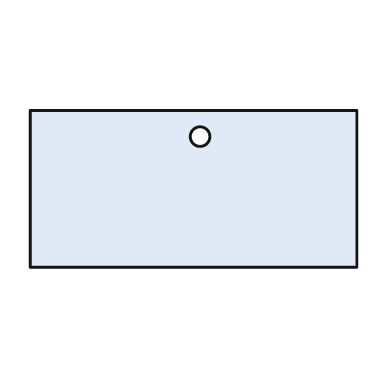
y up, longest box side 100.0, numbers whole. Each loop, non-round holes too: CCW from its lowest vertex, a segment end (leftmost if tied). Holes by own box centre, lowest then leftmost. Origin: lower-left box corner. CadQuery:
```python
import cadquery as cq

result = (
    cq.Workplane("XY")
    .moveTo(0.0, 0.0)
    .lineTo(100.0, 0.0)
    .lineTo(100.0, 48.0)
    .lineTo(0.0, 48.0)
    .close()
    .moveTo(52.0, 40.0)
    .circle(3.0)
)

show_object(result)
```